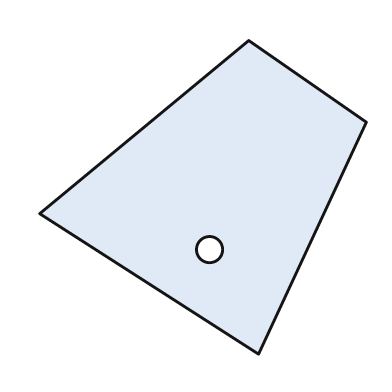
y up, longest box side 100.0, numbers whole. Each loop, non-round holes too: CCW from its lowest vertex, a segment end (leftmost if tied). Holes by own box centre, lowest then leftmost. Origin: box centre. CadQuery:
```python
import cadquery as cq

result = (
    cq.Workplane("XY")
    .moveTo(17.0, -48.0)
    .lineTo(50.0, 23.0)
    .lineTo(14.0, 48.0)
    .lineTo(-50.0, -5.0)
    .close()
    .moveTo(2.0, -16.0)
    .circle(4.0)
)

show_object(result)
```